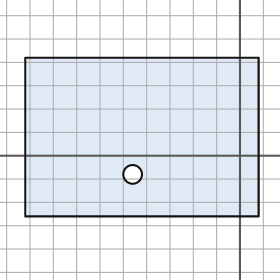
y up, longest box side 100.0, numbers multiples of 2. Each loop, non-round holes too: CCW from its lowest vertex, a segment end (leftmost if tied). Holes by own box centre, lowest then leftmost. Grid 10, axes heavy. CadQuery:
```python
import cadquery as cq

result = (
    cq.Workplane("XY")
    .moveTo(-92.0, -26.0)
    .lineTo(8.0, -26.0)
    .lineTo(8.0, 42.0)
    .lineTo(-92.0, 42.0)
    .close()
    .moveTo(-46.0, -8.0)
    .circle(4.0)
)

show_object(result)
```